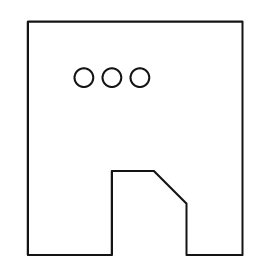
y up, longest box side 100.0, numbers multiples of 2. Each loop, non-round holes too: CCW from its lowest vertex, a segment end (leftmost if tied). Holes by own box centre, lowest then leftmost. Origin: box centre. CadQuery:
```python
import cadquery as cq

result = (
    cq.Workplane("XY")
    .moveTo(-46.0, -50.0)
    .lineTo(-10.0, -50.0)
    .lineTo(-10.0, -14.0)
    .lineTo(8.0, -14.0)
    .lineTo(22.0, -28.0)
    .lineTo(22.0, -50.0)
    .lineTo(46.0, -50.0)
    .lineTo(46.0, 50.0)
    .lineTo(-46.0, 50.0)
    .close()
    .moveTo(-22.0, 26.0)
    .circle(4.0)
    .moveTo(-10.0, 26.0)
    .circle(4.0)
    .moveTo(2.0, 26.0)
    .circle(4.0)
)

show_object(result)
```